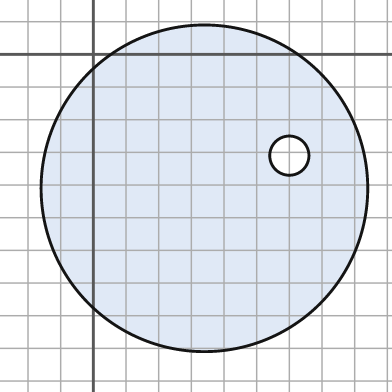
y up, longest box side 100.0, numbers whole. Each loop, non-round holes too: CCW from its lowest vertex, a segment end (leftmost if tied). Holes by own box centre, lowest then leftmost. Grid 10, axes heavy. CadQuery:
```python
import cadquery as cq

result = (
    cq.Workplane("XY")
    .moveTo(34.0, -41.0)
    .circle(50.0)
    .moveTo(60.0, -31.0)
    .circle(6.0)
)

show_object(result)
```